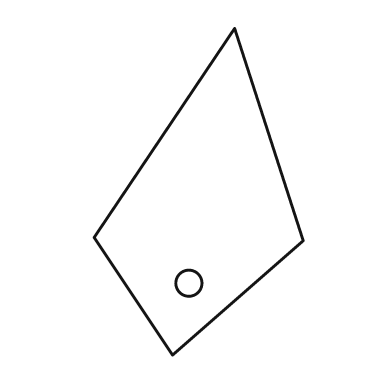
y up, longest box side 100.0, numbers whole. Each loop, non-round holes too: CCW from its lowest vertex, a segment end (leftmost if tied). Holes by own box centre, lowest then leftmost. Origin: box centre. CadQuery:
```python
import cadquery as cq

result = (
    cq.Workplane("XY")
    .moveTo(-8.0, -50.0)
    .lineTo(32.0, -15.0)
    .lineTo(11.0, 50.0)
    .lineTo(-32.0, -14.0)
    .close()
    .moveTo(-3.0, -28.0)
    .circle(4.0)
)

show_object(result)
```